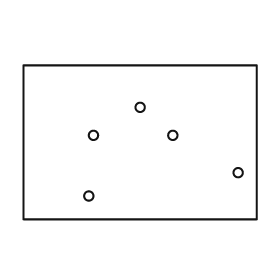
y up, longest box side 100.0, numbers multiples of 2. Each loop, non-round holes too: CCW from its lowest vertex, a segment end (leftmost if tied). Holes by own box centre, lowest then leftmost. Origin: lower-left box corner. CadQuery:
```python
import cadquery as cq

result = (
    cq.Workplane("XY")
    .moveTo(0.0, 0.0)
    .lineTo(100.0, 0.0)
    .lineTo(100.0, 66.0)
    .lineTo(0.0, 66.0)
    .close()
    .moveTo(28.0, 10.0)
    .circle(2.0)
    .moveTo(92.0, 20.0)
    .circle(2.0)
    .moveTo(30.0, 36.0)
    .circle(2.0)
    .moveTo(64.0, 36.0)
    .circle(2.0)
    .moveTo(50.0, 48.0)
    .circle(2.0)
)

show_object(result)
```